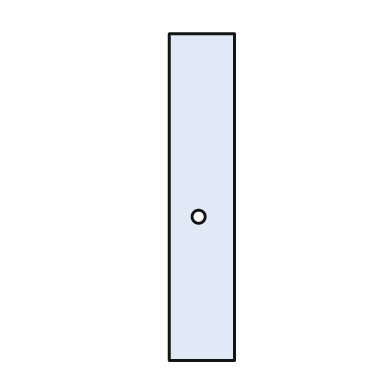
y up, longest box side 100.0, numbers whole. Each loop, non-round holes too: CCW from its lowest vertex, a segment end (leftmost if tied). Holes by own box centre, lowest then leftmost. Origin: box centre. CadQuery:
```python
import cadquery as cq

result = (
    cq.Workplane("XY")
    .moveTo(-10.0, -50.0)
    .lineTo(10.0, -50.0)
    .lineTo(10.0, 50.0)
    .lineTo(-10.0, 50.0)
    .close()
    .moveTo(-1.0, -6.0)
    .circle(2.0)
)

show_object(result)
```